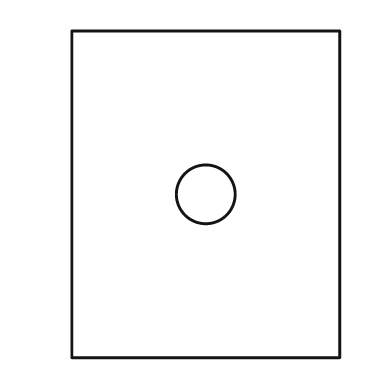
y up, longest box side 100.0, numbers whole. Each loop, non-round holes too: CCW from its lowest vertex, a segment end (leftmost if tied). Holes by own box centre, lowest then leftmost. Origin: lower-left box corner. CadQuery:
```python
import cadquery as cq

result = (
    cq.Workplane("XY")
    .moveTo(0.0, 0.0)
    .lineTo(82.0, 0.0)
    .lineTo(82.0, 100.0)
    .lineTo(0.0, 100.0)
    .close()
    .moveTo(41.0, 50.0)
    .circle(9.0)
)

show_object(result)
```